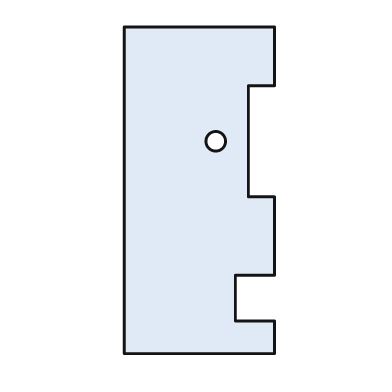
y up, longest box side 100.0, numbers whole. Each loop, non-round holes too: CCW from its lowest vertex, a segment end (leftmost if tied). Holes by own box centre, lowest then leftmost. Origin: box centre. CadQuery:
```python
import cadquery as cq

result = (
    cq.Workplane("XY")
    .moveTo(-23.0, -50.0)
    .lineTo(23.0, -50.0)
    .lineTo(23.0, -40.0)
    .lineTo(11.0, -40.0)
    .lineTo(11.0, -26.0)
    .lineTo(23.0, -26.0)
    .lineTo(23.0, -2.0)
    .lineTo(15.0, -2.0)
    .lineTo(15.0, 32.0)
    .lineTo(23.0, 32.0)
    .lineTo(23.0, 50.0)
    .lineTo(-23.0, 50.0)
    .close()
    .moveTo(5.0, 15.0)
    .circle(3.0)
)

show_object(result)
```